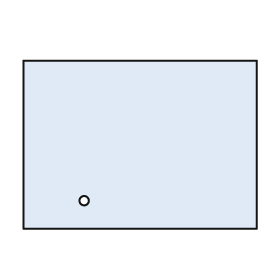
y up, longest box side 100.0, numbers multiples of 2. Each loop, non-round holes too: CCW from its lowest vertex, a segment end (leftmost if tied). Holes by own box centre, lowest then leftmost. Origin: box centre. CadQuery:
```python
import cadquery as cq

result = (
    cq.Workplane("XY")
    .moveTo(-50.0, -36.0)
    .lineTo(50.0, -36.0)
    .lineTo(50.0, 36.0)
    .lineTo(-50.0, 36.0)
    .close()
    .moveTo(-24.0, -24.0)
    .circle(2.0)
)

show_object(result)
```